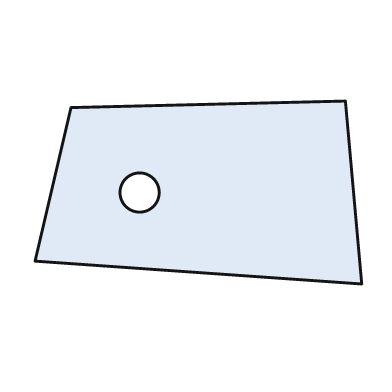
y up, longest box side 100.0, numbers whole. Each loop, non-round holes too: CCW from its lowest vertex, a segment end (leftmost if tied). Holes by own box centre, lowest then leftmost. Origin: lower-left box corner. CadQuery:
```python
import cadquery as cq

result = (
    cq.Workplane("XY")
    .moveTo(100.0, 0.0)
    .lineTo(95.0, 56.0)
    .lineTo(11.0, 54.0)
    .lineTo(0.0, 7.0)
    .close()
    .moveTo(32.0, 28.0)
    .circle(6.0)
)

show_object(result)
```